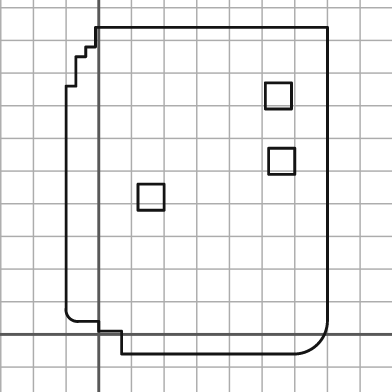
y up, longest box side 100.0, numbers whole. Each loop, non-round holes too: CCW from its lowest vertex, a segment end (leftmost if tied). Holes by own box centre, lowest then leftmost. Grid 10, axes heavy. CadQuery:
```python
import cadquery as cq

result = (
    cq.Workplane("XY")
    .moveTo(7.0, -6.0)
    .lineTo(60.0, -6.0)
    .threePointArc((67.0, -3.0), (70.0, 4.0))
    .lineTo(70.0, 94.0)
    .lineTo(-1.0, 94.0)
    .lineTo(-1.0, 88.0)
    .lineTo(-4.0, 88.0)
    .lineTo(-4.0, 85.0)
    .lineTo(-7.0, 85.0)
    .lineTo(-7.0, 76.0)
    .lineTo(-10.0, 76.0)
    .lineTo(-10.0, 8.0)
    .threePointArc((-9.0, 5.0), (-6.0, 4.0))
    .lineTo(0.0, 4.0)
    .lineTo(0.0, 1.0)
    .lineTo(7.0, 1.0)
    .close()
    .moveTo(12.0, 38.0)
    .lineTo(20.0, 38.0)
    .lineTo(20.0, 46.0)
    .lineTo(12.0, 46.0)
    .close()
    .moveTo(52.0, 49.0)
    .lineTo(60.0, 49.0)
    .lineTo(60.0, 57.0)
    .lineTo(52.0, 57.0)
    .close()
    .moveTo(51.0, 69.0)
    .lineTo(59.0, 69.0)
    .lineTo(59.0, 77.0)
    .lineTo(51.0, 77.0)
    .close()
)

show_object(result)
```